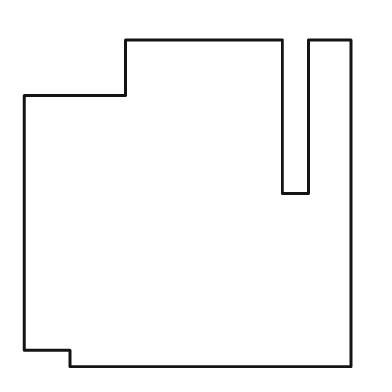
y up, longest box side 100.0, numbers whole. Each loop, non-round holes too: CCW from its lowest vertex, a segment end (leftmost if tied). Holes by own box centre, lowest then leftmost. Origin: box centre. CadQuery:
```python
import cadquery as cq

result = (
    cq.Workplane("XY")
    .moveTo(-36.0, -50.0)
    .lineTo(50.0, -50.0)
    .lineTo(50.0, 50.0)
    .lineTo(37.0, 50.0)
    .lineTo(37.0, 3.0)
    .lineTo(29.0, 3.0)
    .lineTo(29.0, 50.0)
    .lineTo(-19.0, 50.0)
    .lineTo(-19.0, 33.0)
    .lineTo(-50.0, 33.0)
    .lineTo(-50.0, -45.0)
    .lineTo(-36.0, -45.0)
    .close()
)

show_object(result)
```